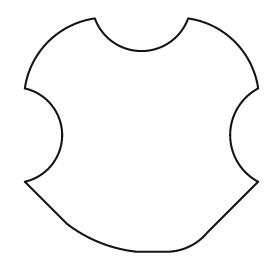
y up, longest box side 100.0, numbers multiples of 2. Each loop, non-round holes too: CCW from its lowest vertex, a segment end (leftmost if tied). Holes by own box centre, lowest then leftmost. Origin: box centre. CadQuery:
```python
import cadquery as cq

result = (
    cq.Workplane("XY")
    .moveTo(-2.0, -50.0)
    .lineTo(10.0, -50.0)
    .threePointArc((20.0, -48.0), (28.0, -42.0))
    .lineTo(50.0, -20.0)
    .threePointArc((38.0, 0.0), (50.0, 20.0))
    .threePointArc((40.0, 40.0), (20.0, 50.0))
    .threePointArc((0.0, 36.0), (-20.0, 50.0))
    .threePointArc((-40.0, 40.0), (-50.0, 20.0))
    .threePointArc((-34.0, 0.0), (-50.0, -20.0))
    .lineTo(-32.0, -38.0)
    .threePointArc((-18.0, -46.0), (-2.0, -50.0))
    .close()
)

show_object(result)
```